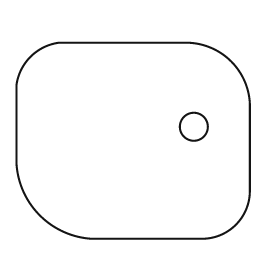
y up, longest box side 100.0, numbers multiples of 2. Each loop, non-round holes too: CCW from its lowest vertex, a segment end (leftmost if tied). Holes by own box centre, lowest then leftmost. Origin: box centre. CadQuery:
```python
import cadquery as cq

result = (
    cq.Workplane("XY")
    .moveTo(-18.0, -42.0)
    .lineTo(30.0, -42.0)
    .threePointArc((44.0, -36.0), (50.0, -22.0))
    .lineTo(50.0, 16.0)
    .threePointArc((42.0, 34.0), (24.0, 42.0))
    .lineTo(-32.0, 42.0)
    .threePointArc((-44.0, 36.0), (-50.0, 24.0))
    .lineTo(-50.0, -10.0)
    .threePointArc((-40.0, -32.0), (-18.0, -42.0))
    .close()
    .moveTo(26.0, 6.0)
    .circle(6.0)
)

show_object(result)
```